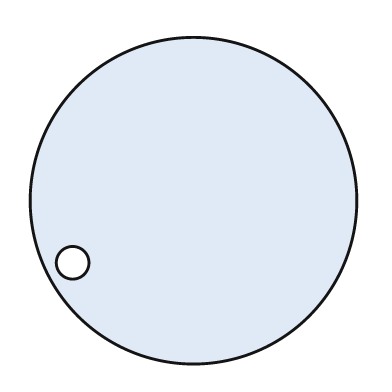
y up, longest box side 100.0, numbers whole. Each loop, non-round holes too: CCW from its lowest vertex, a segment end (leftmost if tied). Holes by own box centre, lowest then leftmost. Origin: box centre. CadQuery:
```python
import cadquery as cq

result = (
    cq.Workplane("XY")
    .moveTo(0.0, 0.0)
    .circle(50.0)
    .moveTo(-37.0, -19.0)
    .circle(5.0)
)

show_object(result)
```